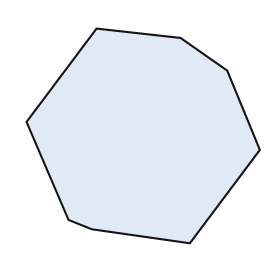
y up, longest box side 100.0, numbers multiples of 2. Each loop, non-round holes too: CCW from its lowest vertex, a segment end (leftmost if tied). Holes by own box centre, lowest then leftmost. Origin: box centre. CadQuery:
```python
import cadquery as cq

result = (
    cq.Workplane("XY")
    .moveTo(20.0, -46.0)
    .lineTo(50.0, -6.0)
    .lineTo(36.0, 28.0)
    .lineTo(16.0, 42.0)
    .lineTo(-20.0, 46.0)
    .lineTo(-50.0, 6.0)
    .lineTo(-32.0, -36.0)
    .lineTo(-22.0, -40.0)
    .close()
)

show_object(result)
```